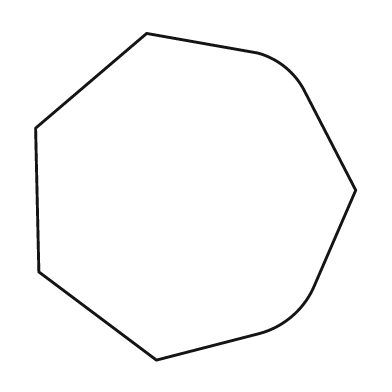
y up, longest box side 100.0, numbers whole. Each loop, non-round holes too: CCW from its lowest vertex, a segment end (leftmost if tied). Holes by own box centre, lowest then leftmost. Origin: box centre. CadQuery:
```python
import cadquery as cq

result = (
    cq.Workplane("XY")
    .moveTo(-12.0, -50.0)
    .lineTo(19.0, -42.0)
    .threePointArc((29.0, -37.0), (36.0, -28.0))
    .lineTo(49.0, 2.0)
    .lineTo(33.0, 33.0)
    .threePointArc((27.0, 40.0), (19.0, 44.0))
    .lineTo(-15.0, 50.0)
    .lineTo(-49.0, 21.0)
    .lineTo(-48.0, -23.0)
    .close()
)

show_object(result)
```